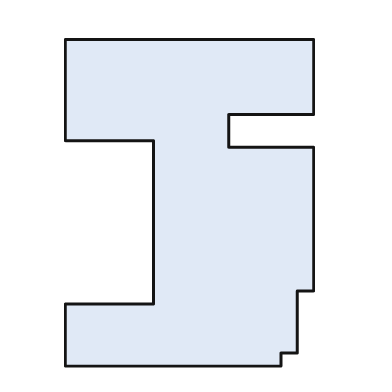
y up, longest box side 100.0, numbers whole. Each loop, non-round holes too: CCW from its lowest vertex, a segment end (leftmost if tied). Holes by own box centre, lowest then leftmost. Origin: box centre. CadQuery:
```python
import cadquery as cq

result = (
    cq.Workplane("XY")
    .moveTo(-38.0, -50.0)
    .lineTo(28.0, -50.0)
    .lineTo(28.0, -46.0)
    .lineTo(33.0, -46.0)
    .lineTo(33.0, -27.0)
    .lineTo(38.0, -27.0)
    .lineTo(38.0, 17.0)
    .lineTo(12.0, 17.0)
    .lineTo(12.0, 27.0)
    .lineTo(38.0, 27.0)
    .lineTo(38.0, 50.0)
    .lineTo(-38.0, 50.0)
    .lineTo(-38.0, 19.0)
    .lineTo(-11.0, 19.0)
    .lineTo(-11.0, -31.0)
    .lineTo(-38.0, -31.0)
    .close()
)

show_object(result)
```